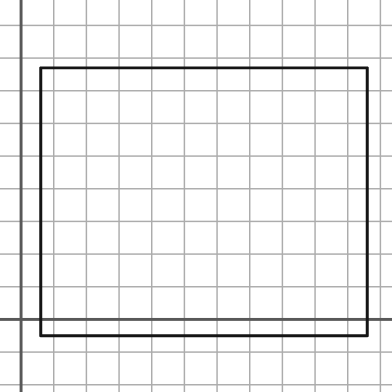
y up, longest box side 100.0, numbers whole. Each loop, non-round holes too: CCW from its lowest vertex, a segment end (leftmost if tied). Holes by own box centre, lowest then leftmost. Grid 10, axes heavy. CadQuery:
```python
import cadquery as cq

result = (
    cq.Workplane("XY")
    .moveTo(6.0, -5.0)
    .lineTo(106.0, -5.0)
    .lineTo(106.0, 77.0)
    .lineTo(6.0, 77.0)
    .close()
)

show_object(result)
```